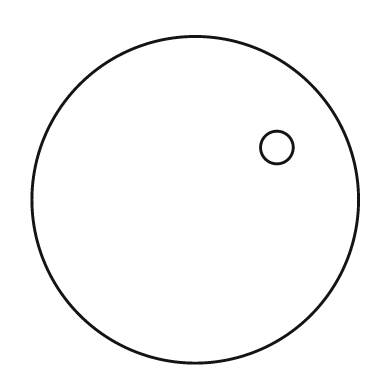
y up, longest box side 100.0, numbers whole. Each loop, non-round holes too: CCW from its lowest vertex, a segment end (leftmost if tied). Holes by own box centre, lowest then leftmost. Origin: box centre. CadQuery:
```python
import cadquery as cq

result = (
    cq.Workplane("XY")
    .moveTo(0.0, 0.0)
    .circle(50.0)
    .moveTo(25.0, 16.0)
    .circle(5.0)
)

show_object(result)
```